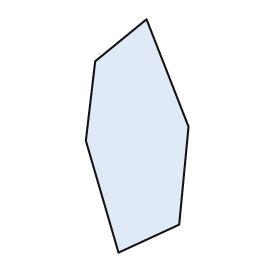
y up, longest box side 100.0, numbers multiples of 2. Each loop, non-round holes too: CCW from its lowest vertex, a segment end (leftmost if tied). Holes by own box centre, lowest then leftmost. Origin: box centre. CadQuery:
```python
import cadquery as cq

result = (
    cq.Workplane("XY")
    .moveTo(-8.0, -50.0)
    .lineTo(18.0, -38.0)
    .lineTo(22.0, 4.0)
    .lineTo(4.0, 50.0)
    .lineTo(-18.0, 32.0)
    .lineTo(-22.0, -2.0)
    .close()
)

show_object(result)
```